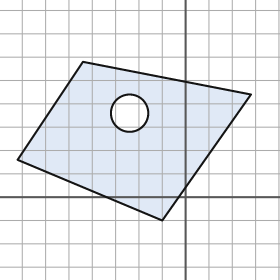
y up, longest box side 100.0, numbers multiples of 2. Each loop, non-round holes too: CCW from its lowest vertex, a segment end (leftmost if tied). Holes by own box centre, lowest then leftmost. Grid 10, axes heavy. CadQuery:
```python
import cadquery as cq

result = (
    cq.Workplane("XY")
    .moveTo(-10.0, -10.0)
    .lineTo(28.0, 44.0)
    .lineTo(-44.0, 58.0)
    .lineTo(-72.0, 16.0)
    .close()
    .moveTo(-24.0, 36.0)
    .circle(8.0)
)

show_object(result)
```